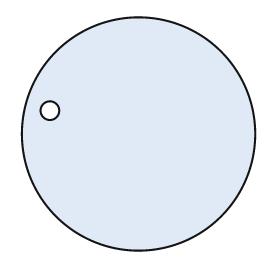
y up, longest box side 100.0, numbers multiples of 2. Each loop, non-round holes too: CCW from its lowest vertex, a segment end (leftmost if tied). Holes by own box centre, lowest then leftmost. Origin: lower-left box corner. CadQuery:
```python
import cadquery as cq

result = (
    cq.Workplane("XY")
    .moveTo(50.0, 50.0)
    .circle(50.0)
    .moveTo(12.0, 60.0)
    .circle(4.0)
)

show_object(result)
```